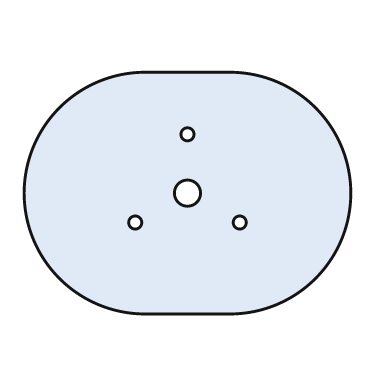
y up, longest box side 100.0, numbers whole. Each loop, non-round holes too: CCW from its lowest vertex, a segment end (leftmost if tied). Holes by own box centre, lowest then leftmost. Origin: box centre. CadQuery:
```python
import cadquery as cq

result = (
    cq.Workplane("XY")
    .moveTo(-13.0, -37.0)
    .lineTo(13.0, -37.0)
    .threePointArc((50.0, 0.0), (13.0, 37.0))
    .lineTo(-13.0, 37.0)
    .threePointArc((-50.0, 0.0), (-13.0, -37.0))
    .close()
    .moveTo(-16.0, -9.0)
    .circle(2.0)
    .moveTo(16.0, -9.0)
    .circle(2.0)
    .moveTo(0.0, 0.0)
    .circle(4.0)
    .moveTo(0.0, 18.0)
    .circle(2.0)
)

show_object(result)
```